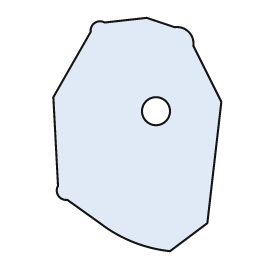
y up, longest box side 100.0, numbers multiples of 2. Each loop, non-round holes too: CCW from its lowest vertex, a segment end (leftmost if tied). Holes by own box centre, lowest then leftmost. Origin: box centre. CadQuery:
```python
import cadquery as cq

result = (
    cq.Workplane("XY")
    .moveTo(14.0, -50.0)
    .lineTo(30.0, -38.0)
    .lineTo(36.0, 14.0)
    .lineTo(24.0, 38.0)
    .threePointArc((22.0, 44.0), (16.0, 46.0))
    .lineTo(4.0, 50.0)
    .lineTo(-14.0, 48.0)
    .threePointArc((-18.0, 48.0), (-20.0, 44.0))
    .lineTo(-36.0, 16.0)
    .lineTo(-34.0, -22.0)
    .threePointArc((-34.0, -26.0), (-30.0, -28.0))
    .lineTo(-16.0, -38.0)
    .threePointArc((-2.0, -46.0), (14.0, -50.0))
    .close()
    .moveTo(8.0, 10.0)
    .circle(6.0)
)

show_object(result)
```